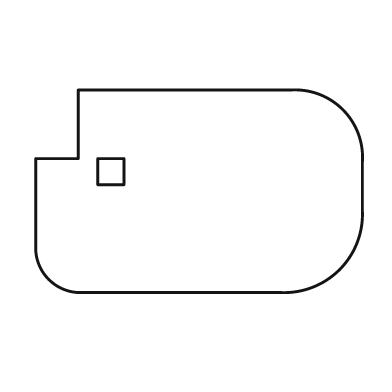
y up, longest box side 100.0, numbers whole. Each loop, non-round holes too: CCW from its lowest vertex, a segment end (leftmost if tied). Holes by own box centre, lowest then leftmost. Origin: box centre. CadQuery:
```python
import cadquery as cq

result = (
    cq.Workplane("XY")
    .moveTo(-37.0, -31.0)
    .lineTo(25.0, -31.0)
    .threePointArc((43.0, -24.0), (50.0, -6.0))
    .lineTo(50.0, 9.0)
    .threePointArc((44.0, 25.0), (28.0, 31.0))
    .lineTo(-37.0, 31.0)
    .lineTo(-37.0, 10.0)
    .lineTo(-50.0, 10.0)
    .lineTo(-50.0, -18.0)
    .threePointArc((-46.0, -27.0), (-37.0, -31.0))
    .close()
    .moveTo(-31.0, 2.0)
    .lineTo(-23.0, 2.0)
    .lineTo(-23.0, 10.0)
    .lineTo(-31.0, 10.0)
    .close()
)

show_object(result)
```